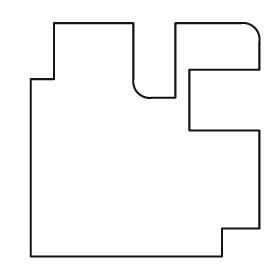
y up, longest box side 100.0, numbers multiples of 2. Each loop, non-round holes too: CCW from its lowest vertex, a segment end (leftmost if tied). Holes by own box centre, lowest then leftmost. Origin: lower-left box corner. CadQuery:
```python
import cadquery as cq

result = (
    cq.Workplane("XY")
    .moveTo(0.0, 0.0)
    .lineTo(82.0, 0.0)
    .lineTo(82.0, 12.0)
    .lineTo(98.0, 12.0)
    .lineTo(98.0, 54.0)
    .lineTo(68.0, 54.0)
    .lineTo(68.0, 80.0)
    .lineTo(98.0, 80.0)
    .lineTo(98.0, 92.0)
    .threePointArc((96.0, 98.0), (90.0, 100.0))
    .lineTo(62.0, 100.0)
    .lineTo(62.0, 68.0)
    .lineTo(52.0, 68.0)
    .threePointArc((46.0, 70.0), (44.0, 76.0))
    .lineTo(44.0, 100.0)
    .lineTo(10.0, 100.0)
    .lineTo(10.0, 76.0)
    .lineTo(0.0, 76.0)
    .close()
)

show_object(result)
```